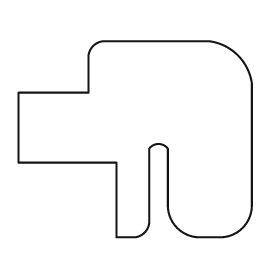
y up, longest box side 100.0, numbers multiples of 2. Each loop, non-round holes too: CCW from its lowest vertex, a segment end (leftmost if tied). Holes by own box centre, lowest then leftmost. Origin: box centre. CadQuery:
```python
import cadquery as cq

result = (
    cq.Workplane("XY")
    .moveTo(-8.0, -42.0)
    .lineTo(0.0, -42.0)
    .threePointArc((4.0, -40.0), (6.0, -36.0))
    .lineTo(6.0, -4.0)
    .threePointArc((10.0, -2.0), (14.0, -4.0))
    .lineTo(14.0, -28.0)
    .threePointArc((18.0, -38.0), (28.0, -42.0))
    .lineTo(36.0, -42.0)
    .threePointArc((46.0, -38.0), (50.0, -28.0))
    .lineTo(50.0, 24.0)
    .threePointArc((44.0, 36.0), (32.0, 42.0))
    .lineTo(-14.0, 42.0)
    .threePointArc((-18.0, 40.0), (-20.0, 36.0))
    .lineTo(-20.0, 20.0)
    .lineTo(-50.0, 20.0)
    .lineTo(-50.0, -10.0)
    .lineTo(-8.0, -10.0)
    .close()
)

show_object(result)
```